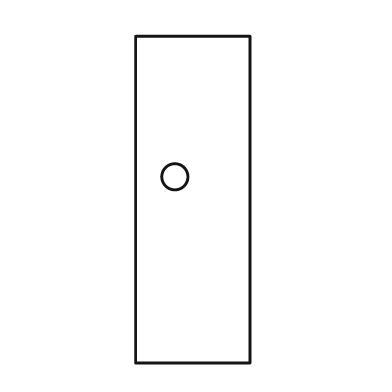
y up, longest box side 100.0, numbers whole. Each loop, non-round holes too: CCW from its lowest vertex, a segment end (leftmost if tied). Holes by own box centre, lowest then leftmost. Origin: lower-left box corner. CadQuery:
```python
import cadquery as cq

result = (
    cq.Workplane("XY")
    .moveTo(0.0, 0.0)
    .lineTo(35.0, 0.0)
    .lineTo(35.0, 100.0)
    .lineTo(0.0, 100.0)
    .close()
    .moveTo(12.0, 57.0)
    .circle(4.0)
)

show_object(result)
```